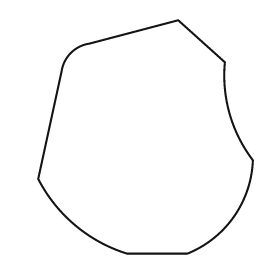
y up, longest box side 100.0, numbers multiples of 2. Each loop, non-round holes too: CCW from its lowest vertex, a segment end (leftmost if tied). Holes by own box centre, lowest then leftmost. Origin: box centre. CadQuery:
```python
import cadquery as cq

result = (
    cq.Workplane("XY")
    .moveTo(-8.0, -50.0)
    .lineTo(18.0, -50.0)
    .threePointArc((38.0, -34.0), (46.0, -10.0))
    .threePointArc((36.0, 10.0), (34.0, 32.0))
    .lineTo(14.0, 50.0)
    .lineTo(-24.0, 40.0)
    .threePointArc((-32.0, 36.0), (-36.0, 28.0))
    .lineTo(-46.0, -18.0)
    .threePointArc((-30.0, -38.0), (-8.0, -50.0))
    .close()
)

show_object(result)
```